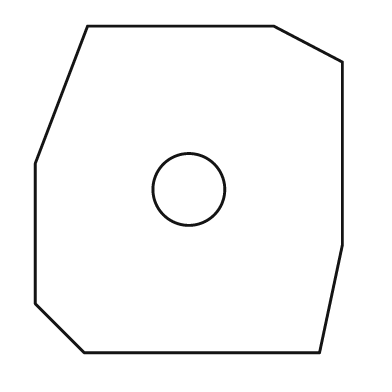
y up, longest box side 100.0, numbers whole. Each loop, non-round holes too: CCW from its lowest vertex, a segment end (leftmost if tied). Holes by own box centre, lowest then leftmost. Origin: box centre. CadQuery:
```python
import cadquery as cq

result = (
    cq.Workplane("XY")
    .moveTo(-32.0, -50.0)
    .lineTo(40.0, -50.0)
    .lineTo(47.0, -17.0)
    .lineTo(47.0, 39.0)
    .lineTo(26.0, 50.0)
    .lineTo(-31.0, 50.0)
    .lineTo(-47.0, 8.0)
    .lineTo(-47.0, -35.0)
    .close()
    .moveTo(0.0, 0.0)
    .circle(11.0)
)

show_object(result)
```